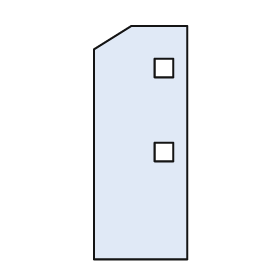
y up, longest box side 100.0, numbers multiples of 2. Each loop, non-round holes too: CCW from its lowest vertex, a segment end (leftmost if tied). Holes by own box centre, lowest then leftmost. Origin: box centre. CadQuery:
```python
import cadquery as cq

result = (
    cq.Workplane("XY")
    .moveTo(-20.0, -50.0)
    .lineTo(20.0, -50.0)
    .lineTo(20.0, 50.0)
    .lineTo(-4.0, 50.0)
    .lineTo(-20.0, 40.0)
    .close()
    .moveTo(6.0, -8.0)
    .lineTo(14.0, -8.0)
    .lineTo(14.0, 0.0)
    .lineTo(6.0, 0.0)
    .close()
    .moveTo(6.0, 28.0)
    .lineTo(14.0, 28.0)
    .lineTo(14.0, 36.0)
    .lineTo(6.0, 36.0)
    .close()
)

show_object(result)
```